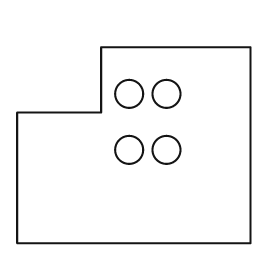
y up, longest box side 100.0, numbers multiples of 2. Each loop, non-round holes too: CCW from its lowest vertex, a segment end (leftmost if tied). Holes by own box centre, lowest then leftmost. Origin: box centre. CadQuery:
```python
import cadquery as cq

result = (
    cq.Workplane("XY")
    .moveTo(-50.0, -42.0)
    .lineTo(50.0, -42.0)
    .lineTo(50.0, 42.0)
    .lineTo(-14.0, 42.0)
    .lineTo(-14.0, 14.0)
    .lineTo(-50.0, 14.0)
    .close()
    .moveTo(-2.0, -2.0)
    .circle(6.0)
    .moveTo(14.0, -2.0)
    .circle(6.0)
    .moveTo(-2.0, 22.0)
    .circle(6.0)
    .moveTo(14.0, 22.0)
    .circle(6.0)
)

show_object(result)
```